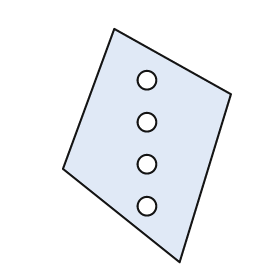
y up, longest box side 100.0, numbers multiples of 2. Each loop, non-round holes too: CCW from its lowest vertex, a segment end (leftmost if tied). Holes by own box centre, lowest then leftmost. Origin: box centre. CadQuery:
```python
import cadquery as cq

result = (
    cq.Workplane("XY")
    .moveTo(14.0, -50.0)
    .lineTo(36.0, 22.0)
    .lineTo(-14.0, 50.0)
    .lineTo(-36.0, -10.0)
    .close()
    .moveTo(0.0, -26.0)
    .circle(4.0)
    .moveTo(0.0, -8.0)
    .circle(4.0)
    .moveTo(0.0, 10.0)
    .circle(4.0)
    .moveTo(0.0, 28.0)
    .circle(4.0)
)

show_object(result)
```